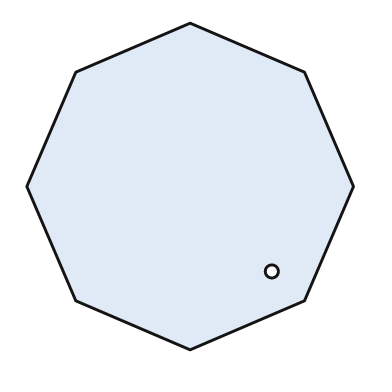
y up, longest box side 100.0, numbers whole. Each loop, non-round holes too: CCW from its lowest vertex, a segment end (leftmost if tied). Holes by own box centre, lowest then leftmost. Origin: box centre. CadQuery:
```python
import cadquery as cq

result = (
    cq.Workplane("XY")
    .moveTo(0.0, -50.0)
    .lineTo(35.0, -35.0)
    .lineTo(50.0, 0.0)
    .lineTo(35.0, 35.0)
    .lineTo(0.0, 50.0)
    .lineTo(-35.0, 35.0)
    .lineTo(-50.0, 0.0)
    .lineTo(-35.0, -35.0)
    .close()
    .moveTo(25.0, -26.0)
    .circle(2.0)
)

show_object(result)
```